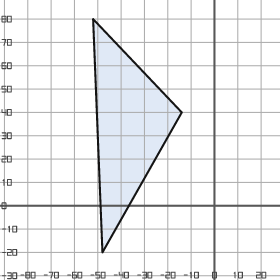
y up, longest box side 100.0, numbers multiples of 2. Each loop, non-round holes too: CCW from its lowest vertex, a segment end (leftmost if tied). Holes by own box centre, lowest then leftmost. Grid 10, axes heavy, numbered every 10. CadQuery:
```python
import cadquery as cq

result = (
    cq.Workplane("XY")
    .moveTo(-48.0, -20.0)
    .lineTo(-14.0, 40.0)
    .lineTo(-52.0, 80.0)
    .close()
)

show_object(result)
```